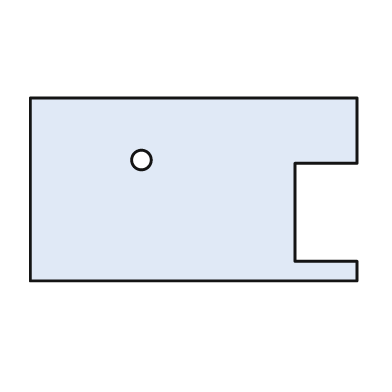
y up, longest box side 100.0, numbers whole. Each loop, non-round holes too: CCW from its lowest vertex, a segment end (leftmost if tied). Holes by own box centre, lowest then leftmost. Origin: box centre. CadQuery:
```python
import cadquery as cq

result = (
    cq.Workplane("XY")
    .moveTo(-50.0, -28.0)
    .lineTo(50.0, -28.0)
    .lineTo(50.0, -22.0)
    .lineTo(31.0, -22.0)
    .lineTo(31.0, 8.0)
    .lineTo(50.0, 8.0)
    .lineTo(50.0, 28.0)
    .lineTo(-50.0, 28.0)
    .close()
    .moveTo(-16.0, 9.0)
    .circle(3.0)
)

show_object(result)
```